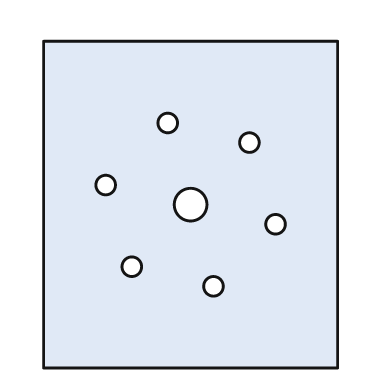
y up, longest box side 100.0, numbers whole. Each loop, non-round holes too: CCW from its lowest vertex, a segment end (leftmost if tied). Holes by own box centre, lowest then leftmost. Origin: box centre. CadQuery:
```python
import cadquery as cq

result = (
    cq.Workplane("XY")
    .moveTo(-45.0, -50.0)
    .lineTo(45.0, -50.0)
    .lineTo(45.0, 50.0)
    .lineTo(-45.0, 50.0)
    .close()
    .moveTo(7.0, -25.0)
    .circle(3.0)
    .moveTo(-18.0, -19.0)
    .circle(3.0)
    .moveTo(26.0, -6.0)
    .circle(3.0)
    .moveTo(0.0, 0.0)
    .circle(5.0)
    .moveTo(-26.0, 6.0)
    .circle(3.0)
    .moveTo(18.0, 19.0)
    .circle(3.0)
    .moveTo(-7.0, 25.0)
    .circle(3.0)
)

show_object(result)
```